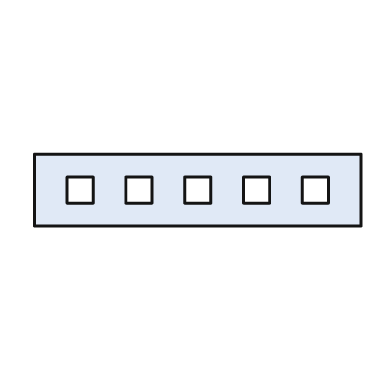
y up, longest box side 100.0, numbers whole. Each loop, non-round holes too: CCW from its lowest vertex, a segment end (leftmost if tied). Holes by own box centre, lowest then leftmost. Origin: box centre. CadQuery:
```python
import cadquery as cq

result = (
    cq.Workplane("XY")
    .moveTo(-50.0, -11.0)
    .lineTo(50.0, -11.0)
    .lineTo(50.0, 11.0)
    .lineTo(-50.0, 11.0)
    .close()
    .moveTo(-40.0, -4.0)
    .lineTo(-32.0, -4.0)
    .lineTo(-32.0, 4.0)
    .lineTo(-40.0, 4.0)
    .close()
    .moveTo(-22.0, -4.0)
    .lineTo(-14.0, -4.0)
    .lineTo(-14.0, 4.0)
    .lineTo(-22.0, 4.0)
    .close()
    .moveTo(-4.0, -4.0)
    .lineTo(4.0, -4.0)
    .lineTo(4.0, 4.0)
    .lineTo(-4.0, 4.0)
    .close()
    .moveTo(14.0, -4.0)
    .lineTo(22.0, -4.0)
    .lineTo(22.0, 4.0)
    .lineTo(14.0, 4.0)
    .close()
    .moveTo(32.0, -4.0)
    .lineTo(40.0, -4.0)
    .lineTo(40.0, 4.0)
    .lineTo(32.0, 4.0)
    .close()
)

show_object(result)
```